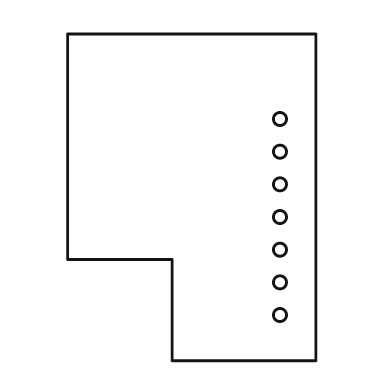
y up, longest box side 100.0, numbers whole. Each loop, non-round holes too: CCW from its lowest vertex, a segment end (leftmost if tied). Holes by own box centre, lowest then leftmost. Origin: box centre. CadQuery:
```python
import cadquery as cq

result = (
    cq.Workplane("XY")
    .moveTo(-6.0, -50.0)
    .lineTo(38.0, -50.0)
    .lineTo(38.0, 50.0)
    .lineTo(-38.0, 50.0)
    .lineTo(-38.0, -19.0)
    .lineTo(-6.0, -19.0)
    .close()
    .moveTo(27.0, -36.0)
    .circle(2.0)
    .moveTo(27.0, -26.0)
    .circle(2.0)
    .moveTo(27.0, -16.0)
    .circle(2.0)
    .moveTo(27.0, -6.0)
    .circle(2.0)
    .moveTo(27.0, 4.0)
    .circle(2.0)
    .moveTo(27.0, 14.0)
    .circle(2.0)
    .moveTo(27.0, 24.0)
    .circle(2.0)
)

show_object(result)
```